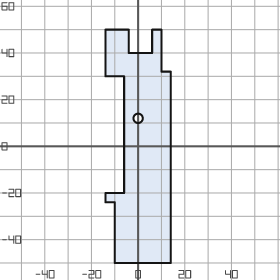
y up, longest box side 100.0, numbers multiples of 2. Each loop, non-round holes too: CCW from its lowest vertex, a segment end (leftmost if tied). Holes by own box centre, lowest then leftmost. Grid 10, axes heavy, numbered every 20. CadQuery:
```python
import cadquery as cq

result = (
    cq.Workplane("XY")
    .moveTo(-10.0, -50.0)
    .lineTo(14.0, -50.0)
    .lineTo(14.0, 32.0)
    .lineTo(10.0, 32.0)
    .lineTo(10.0, 50.0)
    .lineTo(6.0, 50.0)
    .lineTo(6.0, 40.0)
    .lineTo(-4.0, 40.0)
    .lineTo(-4.0, 50.0)
    .lineTo(-14.0, 50.0)
    .lineTo(-14.0, 30.0)
    .lineTo(-6.0, 30.0)
    .lineTo(-6.0, -20.0)
    .lineTo(-14.0, -20.0)
    .lineTo(-14.0, -24.0)
    .lineTo(-10.0, -24.0)
    .close()
    .moveTo(0.0, 12.0)
    .circle(2.0)
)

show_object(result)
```